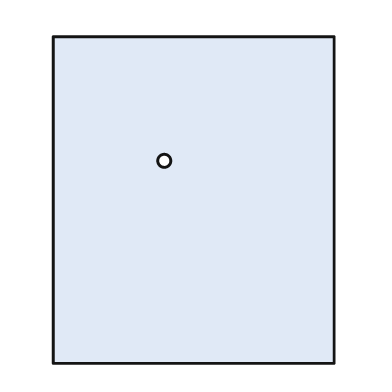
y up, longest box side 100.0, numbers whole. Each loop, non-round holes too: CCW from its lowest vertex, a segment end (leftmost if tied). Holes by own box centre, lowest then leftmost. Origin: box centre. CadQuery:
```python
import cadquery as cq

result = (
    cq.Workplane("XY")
    .moveTo(-43.0, -50.0)
    .lineTo(43.0, -50.0)
    .lineTo(43.0, 50.0)
    .lineTo(-43.0, 50.0)
    .close()
    .moveTo(-9.0, 12.0)
    .circle(2.0)
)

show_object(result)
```